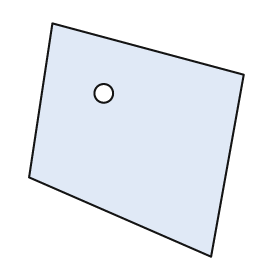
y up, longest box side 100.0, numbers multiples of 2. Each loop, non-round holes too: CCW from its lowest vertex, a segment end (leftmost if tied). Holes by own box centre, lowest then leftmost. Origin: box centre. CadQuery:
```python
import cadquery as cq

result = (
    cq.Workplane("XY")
    .moveTo(32.0, -50.0)
    .lineTo(46.0, 28.0)
    .lineTo(-36.0, 50.0)
    .lineTo(-46.0, -16.0)
    .close()
    .moveTo(-14.0, 20.0)
    .circle(4.0)
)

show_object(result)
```